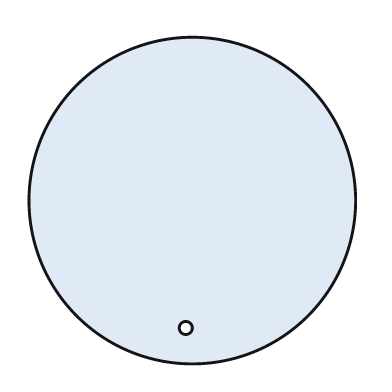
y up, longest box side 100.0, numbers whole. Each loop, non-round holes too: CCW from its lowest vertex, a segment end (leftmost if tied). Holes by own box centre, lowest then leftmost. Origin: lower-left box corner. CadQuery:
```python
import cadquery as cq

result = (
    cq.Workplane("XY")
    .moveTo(50.0, 50.0)
    .circle(50.0)
    .moveTo(48.0, 11.0)
    .circle(2.0)
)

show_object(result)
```